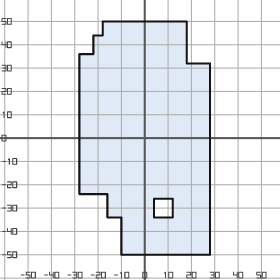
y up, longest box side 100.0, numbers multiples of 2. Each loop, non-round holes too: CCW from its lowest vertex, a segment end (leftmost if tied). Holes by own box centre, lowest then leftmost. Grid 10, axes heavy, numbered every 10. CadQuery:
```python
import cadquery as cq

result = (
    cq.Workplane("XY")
    .moveTo(-10.0, -50.0)
    .lineTo(28.0, -50.0)
    .lineTo(28.0, 32.0)
    .lineTo(18.0, 32.0)
    .lineTo(18.0, 50.0)
    .lineTo(-18.0, 50.0)
    .lineTo(-18.0, 44.0)
    .lineTo(-22.0, 44.0)
    .lineTo(-22.0, 36.0)
    .lineTo(-28.0, 36.0)
    .lineTo(-28.0, -24.0)
    .lineTo(-16.0, -24.0)
    .lineTo(-16.0, -34.0)
    .lineTo(-10.0, -34.0)
    .close()
    .moveTo(4.0, -34.0)
    .lineTo(12.0, -34.0)
    .lineTo(12.0, -26.0)
    .lineTo(4.0, -26.0)
    .close()
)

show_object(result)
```